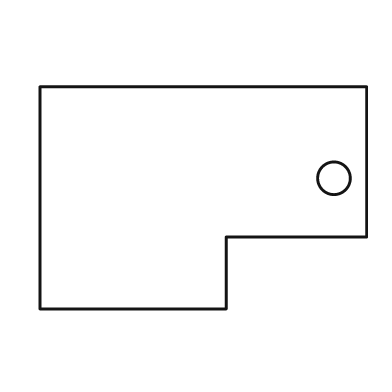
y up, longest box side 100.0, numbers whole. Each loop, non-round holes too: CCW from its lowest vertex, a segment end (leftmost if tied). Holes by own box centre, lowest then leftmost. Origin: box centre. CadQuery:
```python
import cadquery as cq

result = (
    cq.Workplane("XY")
    .moveTo(-50.0, -34.0)
    .lineTo(7.0, -34.0)
    .lineTo(7.0, -12.0)
    .lineTo(50.0, -12.0)
    .lineTo(50.0, 34.0)
    .lineTo(-50.0, 34.0)
    .close()
    .moveTo(40.0, 6.0)
    .circle(5.0)
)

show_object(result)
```